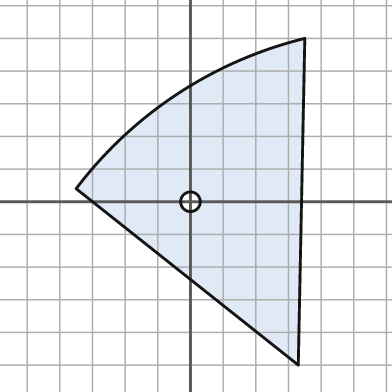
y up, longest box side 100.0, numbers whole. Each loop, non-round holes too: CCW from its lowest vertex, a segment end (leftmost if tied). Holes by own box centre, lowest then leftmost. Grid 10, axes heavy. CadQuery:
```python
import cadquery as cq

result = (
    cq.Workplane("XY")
    .moveTo(33.0, -50.0)
    .lineTo(35.0, 50.0)
    .threePointArc((-4.0, 33.0), (-35.0, 4.0))
    .close()
    .moveTo(0.0, 0.0)
    .circle(3.0)
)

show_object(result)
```